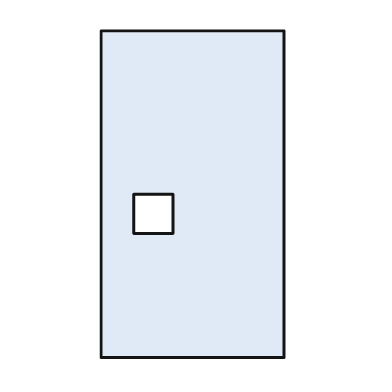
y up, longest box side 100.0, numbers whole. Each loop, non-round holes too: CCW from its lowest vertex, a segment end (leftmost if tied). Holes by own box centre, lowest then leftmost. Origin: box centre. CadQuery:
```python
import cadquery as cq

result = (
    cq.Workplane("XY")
    .moveTo(-28.0, -50.0)
    .lineTo(28.0, -50.0)
    .lineTo(28.0, 50.0)
    .lineTo(-28.0, 50.0)
    .close()
    .moveTo(-18.0, -12.0)
    .lineTo(-6.0, -12.0)
    .lineTo(-6.0, 0.0)
    .lineTo(-18.0, 0.0)
    .close()
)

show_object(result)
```